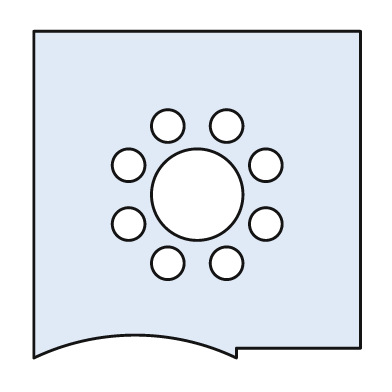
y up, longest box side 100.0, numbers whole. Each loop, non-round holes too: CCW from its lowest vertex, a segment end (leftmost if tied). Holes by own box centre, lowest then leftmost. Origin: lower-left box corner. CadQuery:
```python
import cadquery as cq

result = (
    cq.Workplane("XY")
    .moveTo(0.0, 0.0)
    .threePointArc((31.0, 7.0), (62.0, 0.0))
    .lineTo(62.0, 3.0)
    .lineTo(100.0, 3.0)
    .lineTo(100.0, 100.0)
    .lineTo(0.0, 100.0)
    .close()
    .moveTo(41.0, 29.0)
    .circle(5.0)
    .moveTo(59.0, 29.0)
    .circle(5.0)
    .moveTo(29.0, 41.0)
    .circle(5.0)
    .moveTo(71.0, 41.0)
    .circle(5.0)
    .moveTo(50.0, 50.0)
    .circle(14.0)
    .moveTo(29.0, 59.0)
    .circle(5.0)
    .moveTo(71.0, 59.0)
    .circle(5.0)
    .moveTo(41.0, 71.0)
    .circle(5.0)
    .moveTo(59.0, 71.0)
    .circle(5.0)
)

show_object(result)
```